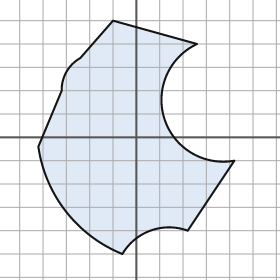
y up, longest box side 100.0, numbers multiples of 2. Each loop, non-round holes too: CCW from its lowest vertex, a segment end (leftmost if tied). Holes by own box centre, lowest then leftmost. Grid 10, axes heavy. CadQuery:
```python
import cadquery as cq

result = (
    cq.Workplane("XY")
    .moveTo(-6.0, -50.0)
    .threePointArc((6.0, -40.0), (22.0, -40.0))
    .lineTo(42.0, -10.0)
    .threePointArc((12.0, 8.0), (26.0, 40.0))
    .lineTo(-10.0, 50.0)
    .lineTo(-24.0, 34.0)
    .threePointArc((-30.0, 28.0), (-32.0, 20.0))
    .lineTo(-42.0, -4.0)
    .threePointArc((-30.0, -32.0), (-6.0, -50.0))
    .close()
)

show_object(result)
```